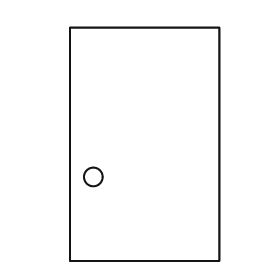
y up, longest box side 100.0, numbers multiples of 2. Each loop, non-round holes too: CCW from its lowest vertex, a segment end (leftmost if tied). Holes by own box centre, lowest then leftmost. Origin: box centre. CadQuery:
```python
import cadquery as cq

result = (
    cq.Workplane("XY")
    .moveTo(-32.0, -50.0)
    .lineTo(32.0, -50.0)
    .lineTo(32.0, 50.0)
    .lineTo(-32.0, 50.0)
    .close()
    .moveTo(-22.0, -14.0)
    .circle(4.0)
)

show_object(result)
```